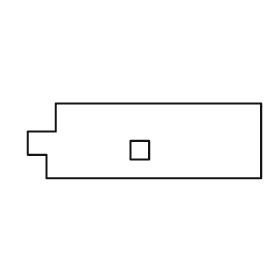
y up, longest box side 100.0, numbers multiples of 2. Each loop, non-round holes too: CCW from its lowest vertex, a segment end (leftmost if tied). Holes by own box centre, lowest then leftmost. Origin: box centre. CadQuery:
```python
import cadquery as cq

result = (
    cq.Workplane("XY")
    .moveTo(-42.0, -16.0)
    .lineTo(50.0, -16.0)
    .lineTo(50.0, 16.0)
    .lineTo(-38.0, 16.0)
    .lineTo(-38.0, 4.0)
    .lineTo(-50.0, 4.0)
    .lineTo(-50.0, -6.0)
    .lineTo(-42.0, -6.0)
    .close()
    .moveTo(-6.0, -8.0)
    .lineTo(2.0, -8.0)
    .lineTo(2.0, 0.0)
    .lineTo(-6.0, 0.0)
    .close()
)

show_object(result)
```